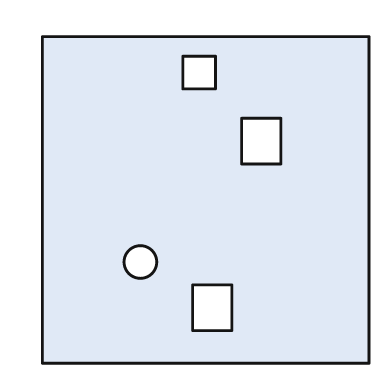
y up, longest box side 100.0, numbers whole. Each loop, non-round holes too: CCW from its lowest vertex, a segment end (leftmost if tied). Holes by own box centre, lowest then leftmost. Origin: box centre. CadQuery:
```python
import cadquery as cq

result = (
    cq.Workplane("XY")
    .moveTo(-50.0, -50.0)
    .lineTo(50.0, -50.0)
    .lineTo(50.0, 50.0)
    .lineTo(-50.0, 50.0)
    .close()
    .moveTo(-4.0, -40.0)
    .lineTo(8.0, -40.0)
    .lineTo(8.0, -26.0)
    .lineTo(-4.0, -26.0)
    .close()
    .moveTo(-20.0, -19.0)
    .circle(5.0)
    .moveTo(11.0, 11.0)
    .lineTo(23.0, 11.0)
    .lineTo(23.0, 25.0)
    .lineTo(11.0, 25.0)
    .close()
    .moveTo(-7.0, 34.0)
    .lineTo(3.0, 34.0)
    .lineTo(3.0, 44.0)
    .lineTo(-7.0, 44.0)
    .close()
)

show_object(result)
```